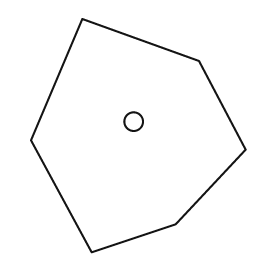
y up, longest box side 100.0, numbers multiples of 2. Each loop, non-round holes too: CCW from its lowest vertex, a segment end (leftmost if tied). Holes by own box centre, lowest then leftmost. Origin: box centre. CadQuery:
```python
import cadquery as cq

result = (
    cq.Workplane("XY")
    .moveTo(-20.0, -50.0)
    .lineTo(16.0, -38.0)
    .lineTo(46.0, -6.0)
    .lineTo(26.0, 32.0)
    .lineTo(-24.0, 50.0)
    .lineTo(-46.0, -2.0)
    .close()
    .moveTo(-2.0, 6.0)
    .circle(4.0)
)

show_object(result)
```